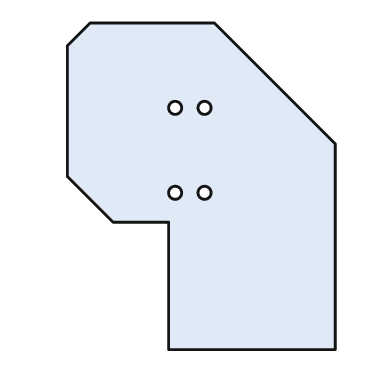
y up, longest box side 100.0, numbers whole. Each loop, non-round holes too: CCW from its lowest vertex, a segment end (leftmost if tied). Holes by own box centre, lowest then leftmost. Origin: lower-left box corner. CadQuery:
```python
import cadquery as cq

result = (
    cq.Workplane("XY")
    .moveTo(31.0, 0.0)
    .lineTo(82.0, 0.0)
    .lineTo(82.0, 63.0)
    .lineTo(45.0, 100.0)
    .lineTo(7.0, 100.0)
    .lineTo(0.0, 93.0)
    .lineTo(0.0, 53.0)
    .lineTo(14.0, 39.0)
    .lineTo(31.0, 39.0)
    .close()
    .moveTo(33.0, 48.0)
    .circle(2.0)
    .moveTo(42.0, 48.0)
    .circle(2.0)
    .moveTo(33.0, 74.0)
    .circle(2.0)
    .moveTo(42.0, 74.0)
    .circle(2.0)
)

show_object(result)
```